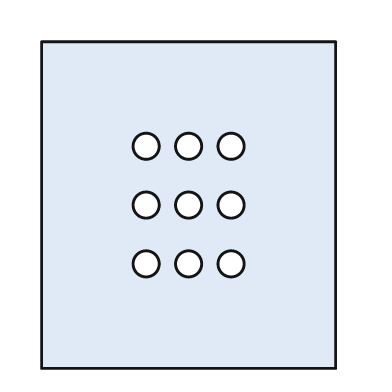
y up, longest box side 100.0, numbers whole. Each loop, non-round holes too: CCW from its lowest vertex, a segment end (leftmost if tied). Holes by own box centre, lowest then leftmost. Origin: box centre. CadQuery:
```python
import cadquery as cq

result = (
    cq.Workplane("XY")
    .moveTo(-45.0, -50.0)
    .lineTo(45.0, -50.0)
    .lineTo(45.0, 50.0)
    .lineTo(-45.0, 50.0)
    .close()
    .moveTo(-13.0, -18.0)
    .circle(4.0)
    .moveTo(0.0, -18.0)
    .circle(4.0)
    .moveTo(13.0, -18.0)
    .circle(4.0)
    .moveTo(-13.0, 0.0)
    .circle(4.0)
    .moveTo(0.0, 0.0)
    .circle(4.0)
    .moveTo(13.0, 0.0)
    .circle(4.0)
    .moveTo(-13.0, 18.0)
    .circle(4.0)
    .moveTo(0.0, 18.0)
    .circle(4.0)
    .moveTo(13.0, 18.0)
    .circle(4.0)
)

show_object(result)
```